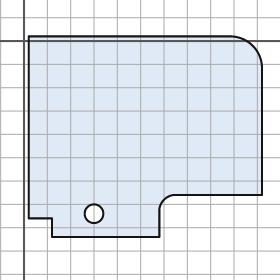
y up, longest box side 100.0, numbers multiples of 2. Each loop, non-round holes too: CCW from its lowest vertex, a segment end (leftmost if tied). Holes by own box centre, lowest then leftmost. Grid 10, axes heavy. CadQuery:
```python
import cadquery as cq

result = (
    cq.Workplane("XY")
    .moveTo(12.0, -84.0)
    .lineTo(58.0, -84.0)
    .lineTo(58.0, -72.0)
    .threePointArc((60.0, -68.0), (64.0, -66.0))
    .lineTo(102.0, -66.0)
    .lineTo(102.0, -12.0)
    .threePointArc((98.0, -2.0), (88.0, 2.0))
    .lineTo(2.0, 2.0)
    .lineTo(2.0, -76.0)
    .lineTo(12.0, -76.0)
    .close()
    .moveTo(30.0, -74.0)
    .circle(4.0)
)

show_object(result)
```